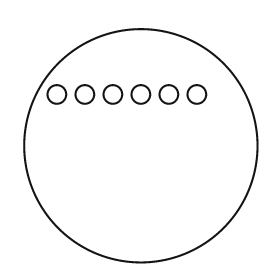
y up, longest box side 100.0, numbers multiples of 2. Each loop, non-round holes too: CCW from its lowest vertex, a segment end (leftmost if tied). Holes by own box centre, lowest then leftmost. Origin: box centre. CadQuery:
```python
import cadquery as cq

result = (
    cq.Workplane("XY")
    .moveTo(0.0, 0.0)
    .circle(50.0)
    .moveTo(-36.0, 22.0)
    .circle(4.0)
    .moveTo(-24.0, 22.0)
    .circle(4.0)
    .moveTo(-12.0, 22.0)
    .circle(4.0)
    .moveTo(0.0, 22.0)
    .circle(4.0)
    .moveTo(12.0, 22.0)
    .circle(4.0)
    .moveTo(24.0, 22.0)
    .circle(4.0)
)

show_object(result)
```